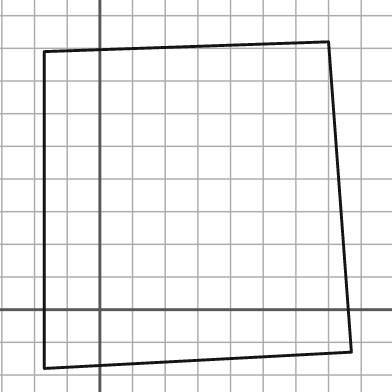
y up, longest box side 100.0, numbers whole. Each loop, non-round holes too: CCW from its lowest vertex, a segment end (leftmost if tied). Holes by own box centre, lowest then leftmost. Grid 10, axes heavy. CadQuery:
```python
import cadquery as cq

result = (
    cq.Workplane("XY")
    .moveTo(-17.0, -18.0)
    .lineTo(77.0, -13.0)
    .lineTo(70.0, 82.0)
    .lineTo(-17.0, 79.0)
    .close()
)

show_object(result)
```